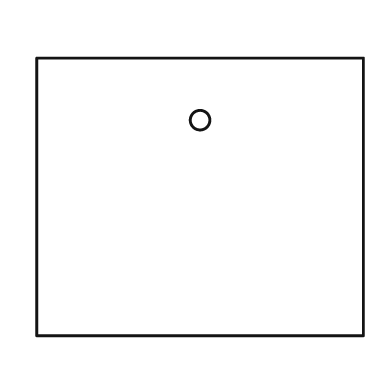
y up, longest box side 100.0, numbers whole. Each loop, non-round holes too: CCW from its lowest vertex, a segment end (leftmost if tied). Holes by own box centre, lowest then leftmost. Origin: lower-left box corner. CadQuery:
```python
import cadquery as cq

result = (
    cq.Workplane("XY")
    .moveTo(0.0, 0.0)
    .lineTo(100.0, 0.0)
    .lineTo(100.0, 85.0)
    .lineTo(0.0, 85.0)
    .close()
    .moveTo(50.0, 66.0)
    .circle(3.0)
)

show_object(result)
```